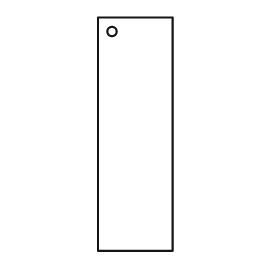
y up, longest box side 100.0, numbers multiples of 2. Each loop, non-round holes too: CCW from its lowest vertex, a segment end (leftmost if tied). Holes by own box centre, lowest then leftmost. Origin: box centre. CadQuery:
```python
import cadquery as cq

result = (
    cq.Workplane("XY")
    .moveTo(-16.0, -50.0)
    .lineTo(16.0, -50.0)
    .lineTo(16.0, 50.0)
    .lineTo(-16.0, 50.0)
    .close()
    .moveTo(-10.0, 44.0)
    .circle(2.0)
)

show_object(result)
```